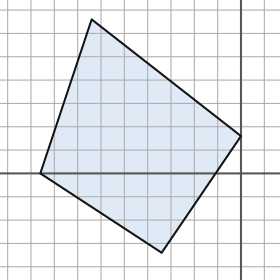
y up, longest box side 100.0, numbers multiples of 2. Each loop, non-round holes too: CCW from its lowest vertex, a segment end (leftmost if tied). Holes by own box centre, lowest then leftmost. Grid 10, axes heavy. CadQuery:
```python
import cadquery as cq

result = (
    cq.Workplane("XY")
    .moveTo(-34.0, -34.0)
    .lineTo(0.0, 16.0)
    .lineTo(-64.0, 66.0)
    .lineTo(-86.0, 0.0)
    .close()
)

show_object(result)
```